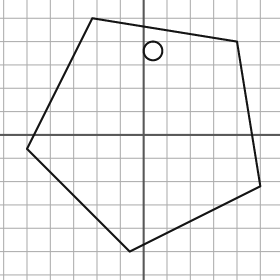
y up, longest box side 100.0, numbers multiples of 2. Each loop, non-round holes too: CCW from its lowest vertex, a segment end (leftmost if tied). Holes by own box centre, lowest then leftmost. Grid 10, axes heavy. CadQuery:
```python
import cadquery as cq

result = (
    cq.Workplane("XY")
    .moveTo(-6.0, -50.0)
    .lineTo(50.0, -22.0)
    .lineTo(40.0, 40.0)
    .lineTo(-22.0, 50.0)
    .lineTo(-50.0, -6.0)
    .close()
    .moveTo(4.0, 36.0)
    .circle(4.0)
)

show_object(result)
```